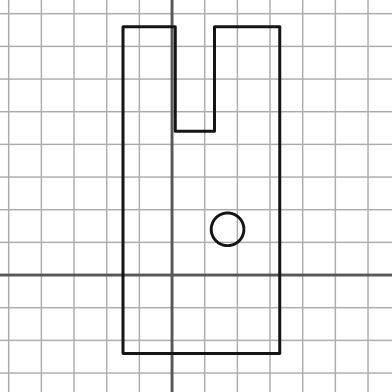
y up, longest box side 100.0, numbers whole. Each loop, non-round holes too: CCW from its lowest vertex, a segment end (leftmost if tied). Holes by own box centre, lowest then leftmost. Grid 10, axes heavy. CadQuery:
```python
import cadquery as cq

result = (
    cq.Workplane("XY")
    .moveTo(-15.0, -24.0)
    .lineTo(33.0, -24.0)
    .lineTo(33.0, 76.0)
    .lineTo(13.0, 76.0)
    .lineTo(13.0, 44.0)
    .lineTo(1.0, 44.0)
    .lineTo(1.0, 76.0)
    .lineTo(-15.0, 76.0)
    .close()
    .moveTo(17.0, 14.0)
    .circle(5.0)
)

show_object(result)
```